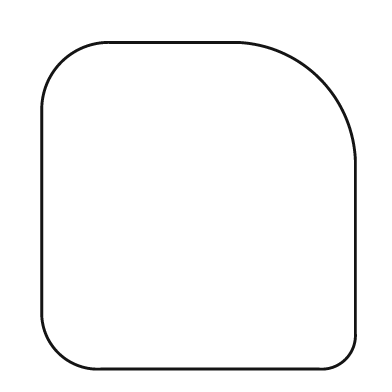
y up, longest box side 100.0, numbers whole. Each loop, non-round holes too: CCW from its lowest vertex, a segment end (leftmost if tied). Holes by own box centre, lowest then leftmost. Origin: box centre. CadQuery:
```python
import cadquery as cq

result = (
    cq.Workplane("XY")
    .moveTo(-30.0, -50.0)
    .lineTo(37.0, -50.0)
    .threePointArc((45.0, -47.0), (48.0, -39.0))
    .lineTo(48.0, 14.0)
    .threePointArc((37.0, 39.0), (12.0, 50.0))
    .lineTo(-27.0, 50.0)
    .threePointArc((-42.0, 44.0), (-48.0, 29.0))
    .lineTo(-48.0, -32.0)
    .threePointArc((-43.0, -45.0), (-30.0, -50.0))
    .close()
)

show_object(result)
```